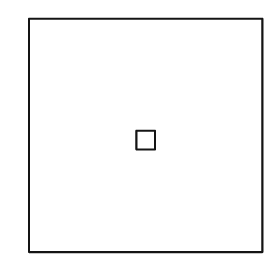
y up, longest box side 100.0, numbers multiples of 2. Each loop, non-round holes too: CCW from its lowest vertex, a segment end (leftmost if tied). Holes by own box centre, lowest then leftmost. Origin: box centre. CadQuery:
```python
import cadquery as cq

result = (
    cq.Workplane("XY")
    .moveTo(-50.0, -50.0)
    .lineTo(50.0, -50.0)
    .lineTo(50.0, 50.0)
    .lineTo(-50.0, 50.0)
    .close()
    .moveTo(-4.0, -6.0)
    .lineTo(4.0, -6.0)
    .lineTo(4.0, 2.0)
    .lineTo(-4.0, 2.0)
    .close()
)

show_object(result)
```